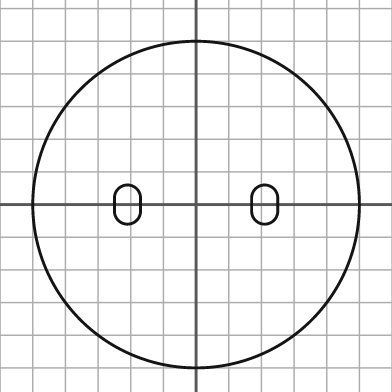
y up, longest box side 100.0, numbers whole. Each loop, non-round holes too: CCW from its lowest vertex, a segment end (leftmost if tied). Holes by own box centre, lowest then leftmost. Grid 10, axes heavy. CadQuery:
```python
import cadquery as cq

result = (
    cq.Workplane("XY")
    .moveTo(0.0, 0.0)
    .circle(50.0)
    .moveTo(-25.0, -2.0)
    .threePointArc((-21.0, -6.0), (-17.0, -2.0))
    .lineTo(-17.0, 2.0)
    .threePointArc((-21.0, 6.0), (-25.0, 2.0))
    .close()
    .moveTo(17.0, -2.0)
    .threePointArc((21.0, -6.0), (25.0, -2.0))
    .lineTo(25.0, 2.0)
    .threePointArc((21.0, 6.0), (17.0, 2.0))
    .close()
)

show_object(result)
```